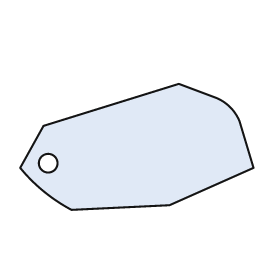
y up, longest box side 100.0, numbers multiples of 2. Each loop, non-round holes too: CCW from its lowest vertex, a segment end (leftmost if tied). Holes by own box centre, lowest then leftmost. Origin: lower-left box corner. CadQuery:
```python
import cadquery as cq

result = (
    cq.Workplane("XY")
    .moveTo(22.0, 0.0)
    .lineTo(64.0, 2.0)
    .lineTo(100.0, 18.0)
    .lineTo(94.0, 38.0)
    .threePointArc((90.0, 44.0), (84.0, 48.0))
    .lineTo(68.0, 54.0)
    .lineTo(10.0, 36.0)
    .lineTo(0.0, 18.0)
    .threePointArc((10.0, 8.0), (22.0, 0.0))
    .close()
    .moveTo(12.0, 20.0)
    .circle(4.0)
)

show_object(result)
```